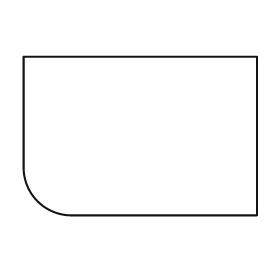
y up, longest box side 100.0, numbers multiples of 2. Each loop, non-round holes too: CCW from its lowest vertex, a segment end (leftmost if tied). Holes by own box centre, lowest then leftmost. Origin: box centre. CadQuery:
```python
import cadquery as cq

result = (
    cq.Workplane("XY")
    .moveTo(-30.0, -34.0)
    .lineTo(50.0, -34.0)
    .lineTo(50.0, 34.0)
    .lineTo(-50.0, 34.0)
    .lineTo(-50.0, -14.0)
    .threePointArc((-44.0, -28.0), (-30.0, -34.0))
    .close()
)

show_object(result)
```